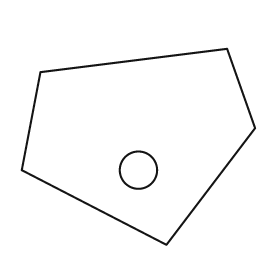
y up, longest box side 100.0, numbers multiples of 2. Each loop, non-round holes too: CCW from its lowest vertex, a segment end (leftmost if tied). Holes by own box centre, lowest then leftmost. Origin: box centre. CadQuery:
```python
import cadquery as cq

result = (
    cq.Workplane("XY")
    .moveTo(12.0, -42.0)
    .lineTo(50.0, 8.0)
    .lineTo(38.0, 42.0)
    .lineTo(-42.0, 32.0)
    .lineTo(-50.0, -10.0)
    .close()
    .moveTo(0.0, -10.0)
    .circle(8.0)
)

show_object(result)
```